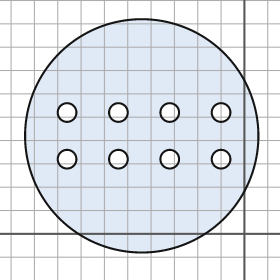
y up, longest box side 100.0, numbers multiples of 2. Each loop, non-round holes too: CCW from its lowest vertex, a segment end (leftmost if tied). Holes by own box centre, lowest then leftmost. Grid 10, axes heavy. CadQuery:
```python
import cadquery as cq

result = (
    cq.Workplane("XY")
    .moveTo(-44.0, 42.0)
    .circle(50.0)
    .moveTo(-76.0, 32.0)
    .circle(4.0)
    .moveTo(-54.0, 32.0)
    .circle(4.0)
    .moveTo(-32.0, 32.0)
    .circle(4.0)
    .moveTo(-10.0, 32.0)
    .circle(4.0)
    .moveTo(-76.0, 52.0)
    .circle(4.0)
    .moveTo(-54.0, 52.0)
    .circle(4.0)
    .moveTo(-32.0, 52.0)
    .circle(4.0)
    .moveTo(-10.0, 52.0)
    .circle(4.0)
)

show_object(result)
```